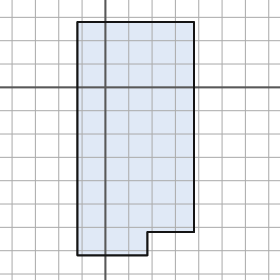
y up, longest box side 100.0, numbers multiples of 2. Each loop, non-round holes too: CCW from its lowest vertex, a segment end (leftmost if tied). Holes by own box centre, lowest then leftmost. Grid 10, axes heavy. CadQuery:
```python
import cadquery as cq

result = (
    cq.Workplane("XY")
    .moveTo(-12.0, -72.0)
    .lineTo(18.0, -72.0)
    .lineTo(18.0, -62.0)
    .lineTo(38.0, -62.0)
    .lineTo(38.0, 28.0)
    .lineTo(-12.0, 28.0)
    .close()
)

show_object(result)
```